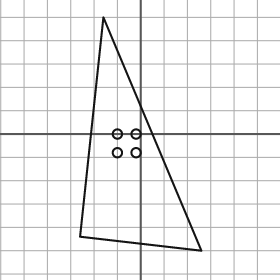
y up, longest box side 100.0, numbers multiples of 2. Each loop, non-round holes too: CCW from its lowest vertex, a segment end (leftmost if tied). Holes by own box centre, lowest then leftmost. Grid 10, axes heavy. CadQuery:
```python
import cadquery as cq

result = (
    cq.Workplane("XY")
    .moveTo(26.0, -50.0)
    .lineTo(-16.0, 50.0)
    .lineTo(-26.0, -44.0)
    .close()
    .moveTo(-10.0, -8.0)
    .circle(2.0)
    .moveTo(-2.0, -8.0)
    .circle(2.0)
    .moveTo(-10.0, 0.0)
    .circle(2.0)
    .moveTo(-2.0, 0.0)
    .circle(2.0)
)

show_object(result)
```